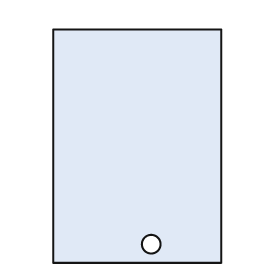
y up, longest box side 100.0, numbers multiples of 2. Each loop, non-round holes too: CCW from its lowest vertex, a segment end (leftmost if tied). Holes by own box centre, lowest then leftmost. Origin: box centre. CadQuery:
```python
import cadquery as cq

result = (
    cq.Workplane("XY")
    .moveTo(-36.0, -50.0)
    .lineTo(36.0, -50.0)
    .lineTo(36.0, 50.0)
    .lineTo(-36.0, 50.0)
    .close()
    .moveTo(6.0, -42.0)
    .circle(4.0)
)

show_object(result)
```